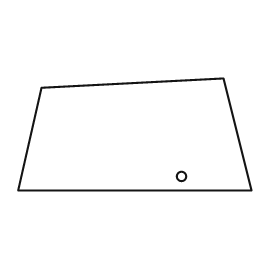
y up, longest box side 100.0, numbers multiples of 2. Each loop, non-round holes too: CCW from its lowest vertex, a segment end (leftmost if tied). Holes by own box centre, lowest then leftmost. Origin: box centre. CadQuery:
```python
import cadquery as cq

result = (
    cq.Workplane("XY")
    .moveTo(-50.0, -24.0)
    .lineTo(50.0, -24.0)
    .lineTo(38.0, 24.0)
    .lineTo(-40.0, 20.0)
    .close()
    .moveTo(20.0, -18.0)
    .circle(2.0)
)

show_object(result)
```